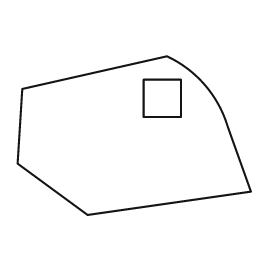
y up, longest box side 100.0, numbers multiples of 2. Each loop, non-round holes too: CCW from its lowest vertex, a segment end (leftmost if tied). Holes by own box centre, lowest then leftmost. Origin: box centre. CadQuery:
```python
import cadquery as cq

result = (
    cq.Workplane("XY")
    .moveTo(-20.0, -34.0)
    .lineTo(50.0, -24.0)
    .lineTo(40.0, 4.0)
    .threePointArc((30.0, 22.0), (14.0, 34.0))
    .lineTo(-48.0, 20.0)
    .lineTo(-50.0, -12.0)
    .close()
    .moveTo(4.0, 8.0)
    .lineTo(20.0, 8.0)
    .lineTo(20.0, 24.0)
    .lineTo(4.0, 24.0)
    .close()
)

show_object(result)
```